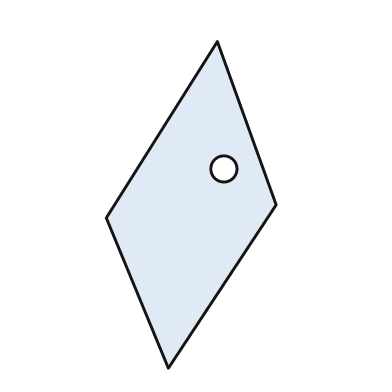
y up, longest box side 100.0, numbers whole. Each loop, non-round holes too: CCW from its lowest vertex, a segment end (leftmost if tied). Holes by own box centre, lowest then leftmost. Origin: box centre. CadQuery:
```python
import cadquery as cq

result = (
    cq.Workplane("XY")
    .moveTo(-7.0, -50.0)
    .lineTo(26.0, 0.0)
    .lineTo(8.0, 50.0)
    .lineTo(-26.0, -4.0)
    .close()
    .moveTo(10.0, 11.0)
    .circle(4.0)
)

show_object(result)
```